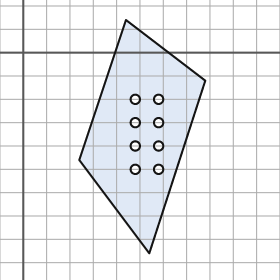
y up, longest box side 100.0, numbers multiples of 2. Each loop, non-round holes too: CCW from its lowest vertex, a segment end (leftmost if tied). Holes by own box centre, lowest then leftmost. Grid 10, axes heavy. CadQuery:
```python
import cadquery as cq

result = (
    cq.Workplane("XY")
    .moveTo(54.0, -86.0)
    .lineTo(78.0, -12.0)
    .lineTo(44.0, 14.0)
    .lineTo(24.0, -46.0)
    .close()
    .moveTo(48.0, -50.0)
    .circle(2.0)
    .moveTo(58.0, -50.0)
    .circle(2.0)
    .moveTo(48.0, -40.0)
    .circle(2.0)
    .moveTo(58.0, -40.0)
    .circle(2.0)
    .moveTo(48.0, -30.0)
    .circle(2.0)
    .moveTo(58.0, -30.0)
    .circle(2.0)
    .moveTo(48.0, -20.0)
    .circle(2.0)
    .moveTo(58.0, -20.0)
    .circle(2.0)
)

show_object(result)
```